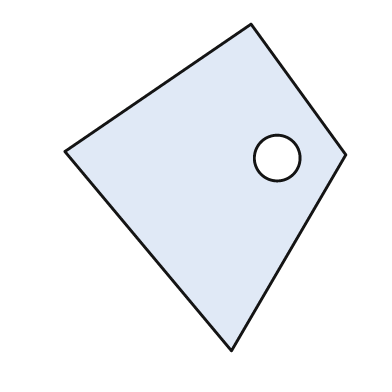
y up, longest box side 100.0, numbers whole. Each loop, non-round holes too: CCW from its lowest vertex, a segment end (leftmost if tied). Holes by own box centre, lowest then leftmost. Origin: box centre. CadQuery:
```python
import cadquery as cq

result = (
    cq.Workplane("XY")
    .moveTo(8.0, -50.0)
    .lineTo(43.0, 10.0)
    .lineTo(14.0, 50.0)
    .lineTo(-43.0, 11.0)
    .close()
    .moveTo(22.0, 9.0)
    .circle(7.0)
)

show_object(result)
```